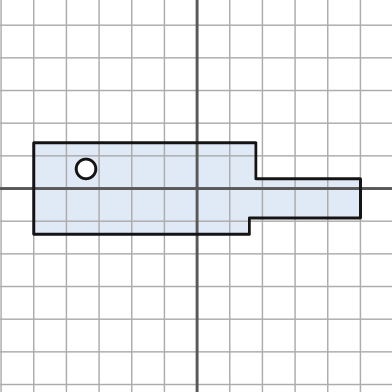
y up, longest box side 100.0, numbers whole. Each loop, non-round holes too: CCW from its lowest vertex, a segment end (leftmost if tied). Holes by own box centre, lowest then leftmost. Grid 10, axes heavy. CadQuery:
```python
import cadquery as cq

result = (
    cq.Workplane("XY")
    .moveTo(-50.0, -14.0)
    .lineTo(16.0, -14.0)
    .lineTo(16.0, -9.0)
    .lineTo(50.0, -9.0)
    .lineTo(50.0, 3.0)
    .lineTo(18.0, 3.0)
    .lineTo(18.0, 14.0)
    .lineTo(-50.0, 14.0)
    .close()
    .moveTo(-34.0, 6.0)
    .circle(3.0)
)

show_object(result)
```